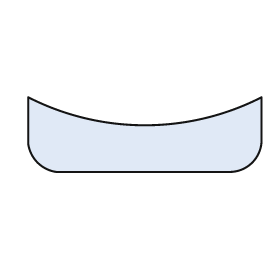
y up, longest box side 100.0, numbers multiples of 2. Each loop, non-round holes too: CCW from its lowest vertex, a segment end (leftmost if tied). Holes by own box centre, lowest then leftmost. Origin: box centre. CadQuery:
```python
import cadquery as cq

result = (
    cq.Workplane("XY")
    .moveTo(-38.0, -16.0)
    .lineTo(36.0, -16.0)
    .threePointArc((46.0, -12.0), (50.0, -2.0))
    .lineTo(50.0, 16.0)
    .threePointArc((0.0, 4.0), (-50.0, 16.0))
    .lineTo(-50.0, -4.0)
    .threePointArc((-46.0, -12.0), (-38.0, -16.0))
    .close()
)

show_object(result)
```